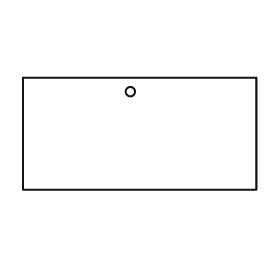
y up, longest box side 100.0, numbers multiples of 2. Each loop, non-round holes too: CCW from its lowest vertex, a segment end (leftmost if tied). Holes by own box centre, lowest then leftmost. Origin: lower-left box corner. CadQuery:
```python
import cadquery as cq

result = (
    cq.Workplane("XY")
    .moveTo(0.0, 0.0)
    .lineTo(100.0, 0.0)
    .lineTo(100.0, 48.0)
    .lineTo(0.0, 48.0)
    .close()
    .moveTo(46.0, 42.0)
    .circle(2.0)
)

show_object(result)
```